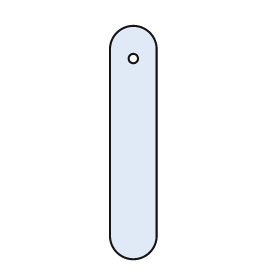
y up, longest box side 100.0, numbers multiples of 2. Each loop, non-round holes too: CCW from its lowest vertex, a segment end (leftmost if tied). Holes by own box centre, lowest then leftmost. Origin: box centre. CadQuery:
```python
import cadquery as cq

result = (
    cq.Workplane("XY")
    .moveTo(-10.0, -40.0)
    .threePointArc((0.0, -50.0), (10.0, -40.0))
    .lineTo(10.0, 40.0)
    .threePointArc((0.0, 50.0), (-10.0, 40.0))
    .close()
    .moveTo(0.0, 36.0)
    .circle(2.0)
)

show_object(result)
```